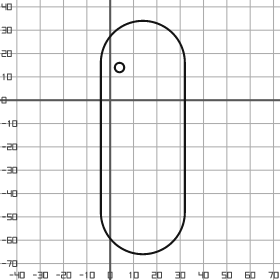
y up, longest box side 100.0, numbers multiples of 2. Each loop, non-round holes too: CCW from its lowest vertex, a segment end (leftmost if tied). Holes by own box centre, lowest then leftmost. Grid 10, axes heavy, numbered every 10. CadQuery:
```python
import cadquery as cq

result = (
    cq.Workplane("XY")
    .moveTo(-4.0, -48.0)
    .threePointArc((14.0, -66.0), (32.0, -48.0))
    .lineTo(32.0, 16.0)
    .threePointArc((14.0, 34.0), (-4.0, 16.0))
    .close()
    .moveTo(4.0, 14.0)
    .circle(2.0)
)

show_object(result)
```